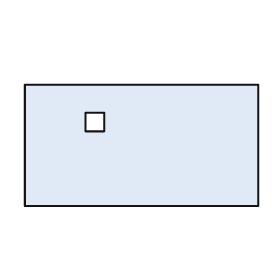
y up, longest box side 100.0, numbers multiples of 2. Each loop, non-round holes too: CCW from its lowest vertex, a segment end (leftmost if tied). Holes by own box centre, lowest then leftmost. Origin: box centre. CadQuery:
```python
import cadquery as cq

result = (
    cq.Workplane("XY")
    .moveTo(-50.0, -26.0)
    .lineTo(50.0, -26.0)
    .lineTo(50.0, 26.0)
    .lineTo(-50.0, 26.0)
    .close()
    .moveTo(-24.0, 6.0)
    .lineTo(-16.0, 6.0)
    .lineTo(-16.0, 14.0)
    .lineTo(-24.0, 14.0)
    .close()
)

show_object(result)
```